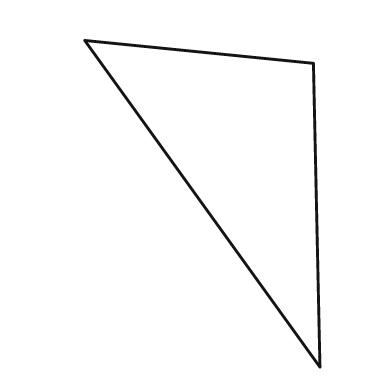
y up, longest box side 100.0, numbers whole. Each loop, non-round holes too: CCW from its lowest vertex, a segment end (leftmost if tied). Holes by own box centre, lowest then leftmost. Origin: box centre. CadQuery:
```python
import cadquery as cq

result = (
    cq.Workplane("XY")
    .moveTo(36.0, -50.0)
    .lineTo(34.0, 43.0)
    .lineTo(-36.0, 50.0)
    .close()
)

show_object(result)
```